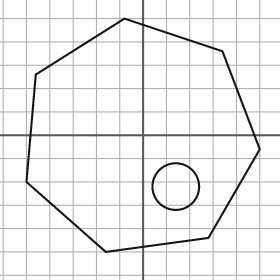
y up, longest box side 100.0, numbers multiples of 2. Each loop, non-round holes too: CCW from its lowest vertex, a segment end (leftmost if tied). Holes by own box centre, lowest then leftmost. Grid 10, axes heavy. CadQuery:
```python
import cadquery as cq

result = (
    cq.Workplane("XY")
    .moveTo(-16.0, -50.0)
    .lineTo(28.0, -44.0)
    .lineTo(50.0, -6.0)
    .lineTo(34.0, 36.0)
    .lineTo(-8.0, 50.0)
    .lineTo(-46.0, 26.0)
    .lineTo(-50.0, -20.0)
    .close()
    .moveTo(14.0, -22.0)
    .circle(10.0)
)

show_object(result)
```